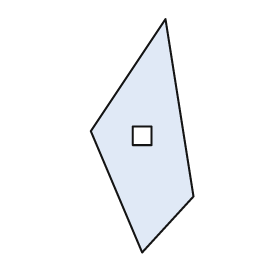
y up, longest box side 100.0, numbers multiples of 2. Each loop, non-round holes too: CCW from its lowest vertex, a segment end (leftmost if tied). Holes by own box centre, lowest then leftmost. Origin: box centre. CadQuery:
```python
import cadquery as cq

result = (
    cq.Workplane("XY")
    .moveTo(0.0, -50.0)
    .lineTo(22.0, -26.0)
    .lineTo(10.0, 50.0)
    .lineTo(-22.0, 2.0)
    .close()
    .moveTo(-4.0, -4.0)
    .lineTo(4.0, -4.0)
    .lineTo(4.0, 4.0)
    .lineTo(-4.0, 4.0)
    .close()
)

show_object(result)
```